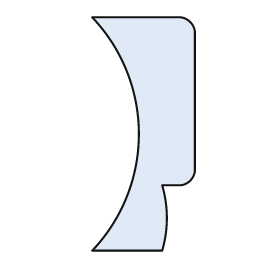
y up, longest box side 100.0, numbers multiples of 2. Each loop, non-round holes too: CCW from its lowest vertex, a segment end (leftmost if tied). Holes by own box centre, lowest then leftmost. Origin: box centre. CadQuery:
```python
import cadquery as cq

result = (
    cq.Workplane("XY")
    .moveTo(-22.0, -50.0)
    .lineTo(8.0, -50.0)
    .threePointArc((10.0, -36.0), (8.0, -22.0))
    .lineTo(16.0, -22.0)
    .threePointArc((20.0, -20.0), (22.0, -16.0))
    .lineTo(22.0, 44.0)
    .threePointArc((20.0, 48.0), (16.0, 50.0))
    .lineTo(-22.0, 50.0)
    .threePointArc((-2.0, 0.0), (-22.0, -50.0))
    .close()
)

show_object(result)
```